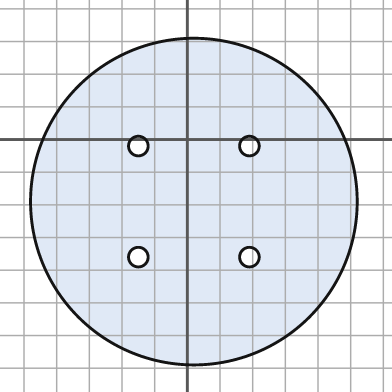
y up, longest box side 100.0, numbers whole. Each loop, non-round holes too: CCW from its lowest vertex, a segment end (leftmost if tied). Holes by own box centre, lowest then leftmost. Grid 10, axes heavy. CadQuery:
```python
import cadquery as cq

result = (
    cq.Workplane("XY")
    .moveTo(2.0, -19.0)
    .circle(50.0)
    .moveTo(-15.0, -36.0)
    .circle(3.0)
    .moveTo(19.0, -36.0)
    .circle(3.0)
    .moveTo(-15.0, -2.0)
    .circle(3.0)
    .moveTo(19.0, -2.0)
    .circle(3.0)
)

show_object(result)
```